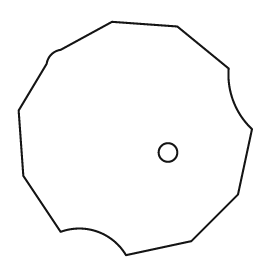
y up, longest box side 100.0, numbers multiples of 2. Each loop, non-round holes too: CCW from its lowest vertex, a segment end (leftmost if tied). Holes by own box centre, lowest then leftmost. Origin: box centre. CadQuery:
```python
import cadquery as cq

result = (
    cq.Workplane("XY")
    .moveTo(-4.0, -50.0)
    .lineTo(24.0, -44.0)
    .lineTo(44.0, -24.0)
    .lineTo(50.0, 4.0)
    .threePointArc((42.0, 16.0), (40.0, 30.0))
    .lineTo(18.0, 48.0)
    .lineTo(-10.0, 50.0)
    .lineTo(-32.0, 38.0)
    .threePointArc((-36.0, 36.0), (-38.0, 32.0))
    .lineTo(-50.0, 12.0)
    .lineTo(-48.0, -16.0)
    .lineTo(-32.0, -40.0)
    .threePointArc((-16.0, -40.0), (-4.0, -50.0))
    .close()
    .moveTo(14.0, -6.0)
    .circle(4.0)
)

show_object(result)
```